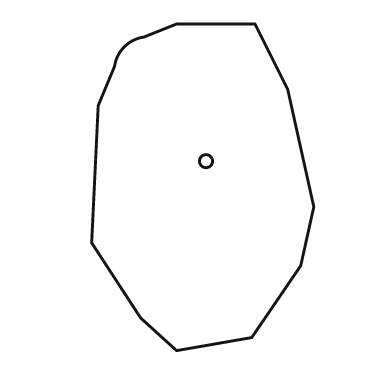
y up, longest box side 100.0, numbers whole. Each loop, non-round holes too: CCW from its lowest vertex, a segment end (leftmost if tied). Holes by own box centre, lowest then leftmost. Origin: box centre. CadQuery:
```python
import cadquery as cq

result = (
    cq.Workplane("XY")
    .moveTo(-8.0, -50.0)
    .lineTo(15.0, -46.0)
    .lineTo(30.0, -24.0)
    .lineTo(34.0, -6.0)
    .lineTo(26.0, 30.0)
    .lineTo(16.0, 50.0)
    .lineTo(-8.0, 50.0)
    .lineTo(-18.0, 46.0)
    .threePointArc((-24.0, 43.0), (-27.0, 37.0))
    .lineTo(-32.0, 25.0)
    .lineTo(-34.0, -17.0)
    .lineTo(-19.0, -40.0)
    .close()
    .moveTo(1.0, 8.0)
    .circle(2.0)
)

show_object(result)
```